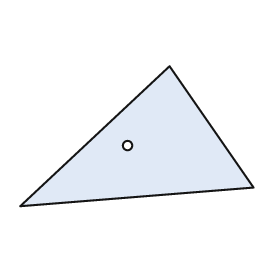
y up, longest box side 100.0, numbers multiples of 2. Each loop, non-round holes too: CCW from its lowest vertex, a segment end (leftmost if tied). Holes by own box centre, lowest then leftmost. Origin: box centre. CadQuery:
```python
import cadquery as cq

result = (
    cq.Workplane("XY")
    .moveTo(-50.0, -30.0)
    .lineTo(50.0, -22.0)
    .lineTo(14.0, 30.0)
    .close()
    .moveTo(-4.0, -4.0)
    .circle(2.0)
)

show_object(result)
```